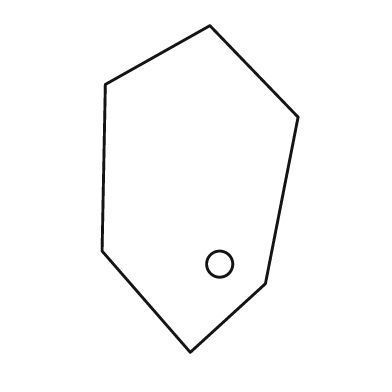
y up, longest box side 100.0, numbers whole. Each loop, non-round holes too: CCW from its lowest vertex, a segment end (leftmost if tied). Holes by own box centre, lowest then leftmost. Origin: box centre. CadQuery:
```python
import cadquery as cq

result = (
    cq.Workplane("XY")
    .moveTo(-3.0, -50.0)
    .lineTo(20.0, -29.0)
    .lineTo(30.0, 22.0)
    .lineTo(3.0, 50.0)
    .lineTo(-29.0, 32.0)
    .lineTo(-30.0, -19.0)
    .close()
    .moveTo(6.0, -23.0)
    .circle(4.0)
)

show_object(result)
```